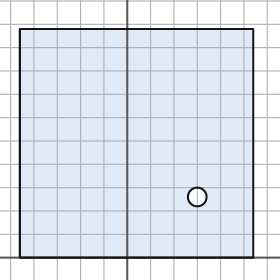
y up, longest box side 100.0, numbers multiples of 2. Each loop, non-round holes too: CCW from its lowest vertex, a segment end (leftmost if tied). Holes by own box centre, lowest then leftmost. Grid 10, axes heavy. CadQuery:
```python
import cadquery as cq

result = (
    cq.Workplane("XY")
    .moveTo(-46.0, 0.0)
    .lineTo(54.0, 0.0)
    .lineTo(54.0, 98.0)
    .lineTo(-46.0, 98.0)
    .close()
    .moveTo(30.0, 26.0)
    .circle(4.0)
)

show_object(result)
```